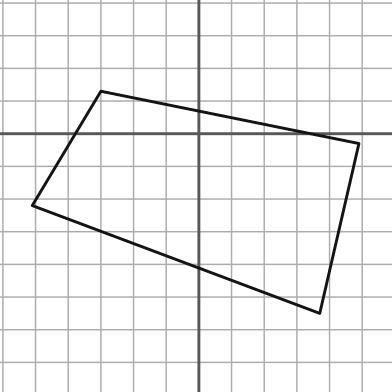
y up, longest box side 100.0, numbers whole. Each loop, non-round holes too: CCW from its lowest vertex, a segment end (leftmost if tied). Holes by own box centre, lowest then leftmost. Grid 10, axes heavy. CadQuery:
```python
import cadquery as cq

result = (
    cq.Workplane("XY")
    .moveTo(37.0, -55.0)
    .lineTo(49.0, -3.0)
    .lineTo(-30.0, 13.0)
    .lineTo(-51.0, -22.0)
    .close()
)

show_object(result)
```